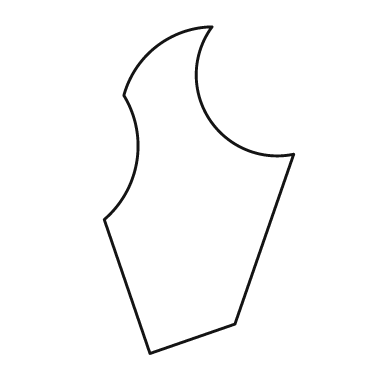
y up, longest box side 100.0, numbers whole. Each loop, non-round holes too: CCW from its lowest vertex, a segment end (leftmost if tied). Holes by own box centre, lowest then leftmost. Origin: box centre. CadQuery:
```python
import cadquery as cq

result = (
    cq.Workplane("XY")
    .moveTo(-15.0, -50.0)
    .lineTo(11.0, -41.0)
    .lineTo(29.0, 11.0)
    .threePointArc((3.0, 22.0), (4.0, 50.0))
    .threePointArc((-13.0, 44.0), (-23.0, 29.0))
    .threePointArc((-19.0, 9.0), (-29.0, -9.0))
    .close()
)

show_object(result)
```